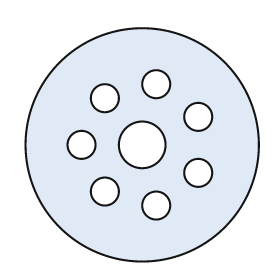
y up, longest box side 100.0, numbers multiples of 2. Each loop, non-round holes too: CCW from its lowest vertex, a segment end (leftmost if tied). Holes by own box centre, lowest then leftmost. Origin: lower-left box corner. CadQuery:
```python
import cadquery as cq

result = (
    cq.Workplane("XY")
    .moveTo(50.0, 50.0)
    .circle(50.0)
    .moveTo(56.0, 24.0)
    .circle(6.0)
    .moveTo(34.0, 30.0)
    .circle(6.0)
    .moveTo(74.0, 38.0)
    .circle(6.0)
    .moveTo(24.0, 50.0)
    .circle(6.0)
    .moveTo(50.0, 50.0)
    .circle(10.0)
    .moveTo(74.0, 62.0)
    .circle(6.0)
    .moveTo(34.0, 70.0)
    .circle(6.0)
    .moveTo(56.0, 76.0)
    .circle(6.0)
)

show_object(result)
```